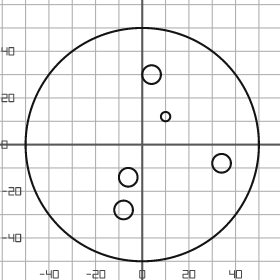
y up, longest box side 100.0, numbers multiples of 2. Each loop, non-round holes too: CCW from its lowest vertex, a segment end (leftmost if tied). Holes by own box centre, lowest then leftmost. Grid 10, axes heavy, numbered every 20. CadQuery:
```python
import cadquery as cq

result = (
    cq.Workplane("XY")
    .moveTo(0.0, 0.0)
    .circle(50.0)
    .moveTo(-8.0, -28.0)
    .circle(4.0)
    .moveTo(-6.0, -14.0)
    .circle(4.0)
    .moveTo(34.0, -8.0)
    .circle(4.0)
    .moveTo(10.0, 12.0)
    .circle(2.0)
    .moveTo(4.0, 30.0)
    .circle(4.0)
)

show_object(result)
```